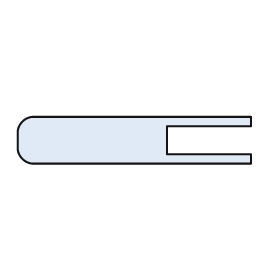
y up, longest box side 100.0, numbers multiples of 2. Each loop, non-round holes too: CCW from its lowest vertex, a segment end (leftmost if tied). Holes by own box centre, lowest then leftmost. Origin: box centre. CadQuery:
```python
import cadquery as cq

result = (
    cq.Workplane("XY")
    .moveTo(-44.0, -10.0)
    .lineTo(50.0, -10.0)
    .lineTo(50.0, -6.0)
    .lineTo(14.0, -6.0)
    .lineTo(14.0, 6.0)
    .lineTo(50.0, 6.0)
    .lineTo(50.0, 10.0)
    .lineTo(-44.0, 10.0)
    .threePointArc((-48.0, 8.0), (-50.0, 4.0))
    .lineTo(-50.0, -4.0)
    .threePointArc((-48.0, -8.0), (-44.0, -10.0))
    .close()
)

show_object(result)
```